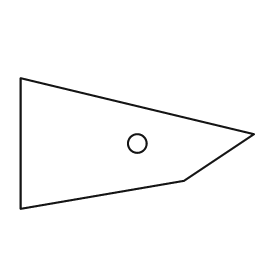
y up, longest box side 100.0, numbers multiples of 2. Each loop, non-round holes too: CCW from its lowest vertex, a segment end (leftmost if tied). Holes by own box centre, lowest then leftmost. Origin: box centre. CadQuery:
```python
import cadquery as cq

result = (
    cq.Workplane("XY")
    .moveTo(-50.0, -28.0)
    .lineTo(20.0, -16.0)
    .lineTo(50.0, 4.0)
    .lineTo(-50.0, 28.0)
    .close()
    .moveTo(0.0, 0.0)
    .circle(4.0)
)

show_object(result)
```